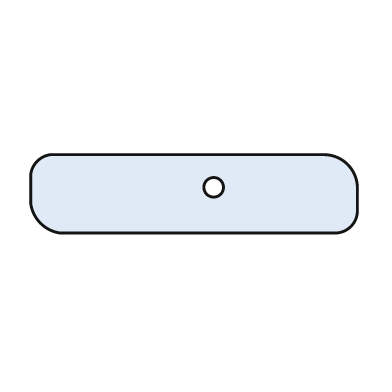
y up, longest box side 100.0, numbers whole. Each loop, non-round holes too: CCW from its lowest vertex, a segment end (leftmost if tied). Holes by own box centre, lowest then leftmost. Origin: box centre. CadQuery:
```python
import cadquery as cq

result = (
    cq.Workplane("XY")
    .moveTo(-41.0, -12.0)
    .lineTo(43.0, -12.0)
    .threePointArc((48.0, -10.0), (50.0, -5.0))
    .lineTo(50.0, 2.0)
    .threePointArc((47.0, 9.0), (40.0, 12.0))
    .lineTo(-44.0, 12.0)
    .threePointArc((-48.0, 10.0), (-50.0, 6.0))
    .lineTo(-50.0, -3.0)
    .threePointArc((-47.0, -9.0), (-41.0, -12.0))
    .close()
    .moveTo(6.0, 2.0)
    .circle(3.0)
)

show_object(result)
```